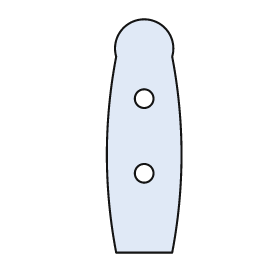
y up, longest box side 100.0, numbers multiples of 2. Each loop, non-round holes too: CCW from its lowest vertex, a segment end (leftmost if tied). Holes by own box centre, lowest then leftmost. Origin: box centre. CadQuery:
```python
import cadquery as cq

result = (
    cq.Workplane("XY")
    .moveTo(-12.0, -50.0)
    .lineTo(12.0, -50.0)
    .threePointArc((16.0, -8.0), (12.0, 34.0))
    .threePointArc((0.0, 50.0), (-12.0, 34.0))
    .threePointArc((-16.0, -8.0), (-12.0, -50.0))
    .close()
    .moveTo(0.0, -16.0)
    .circle(4.0)
    .moveTo(0.0, 16.0)
    .circle(4.0)
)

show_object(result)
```